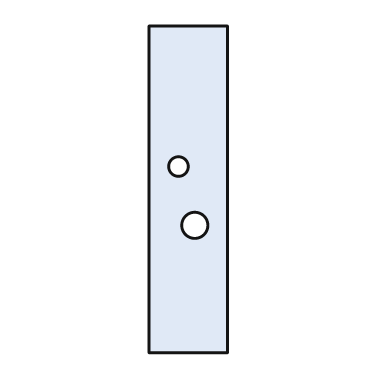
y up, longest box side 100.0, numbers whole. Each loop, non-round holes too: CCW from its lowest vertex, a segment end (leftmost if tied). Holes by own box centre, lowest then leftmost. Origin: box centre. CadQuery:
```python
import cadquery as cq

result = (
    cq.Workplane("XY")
    .moveTo(-12.0, -50.0)
    .lineTo(12.0, -50.0)
    .lineTo(12.0, 50.0)
    .lineTo(-12.0, 50.0)
    .close()
    .moveTo(2.0, -11.0)
    .circle(4.0)
    .moveTo(-3.0, 7.0)
    .circle(3.0)
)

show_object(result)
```